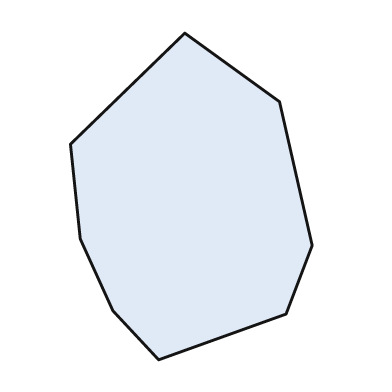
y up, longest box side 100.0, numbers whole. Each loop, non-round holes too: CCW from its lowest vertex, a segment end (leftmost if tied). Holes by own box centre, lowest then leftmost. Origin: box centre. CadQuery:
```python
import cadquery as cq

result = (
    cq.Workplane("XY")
    .moveTo(-10.0, -50.0)
    .lineTo(29.0, -36.0)
    .lineTo(37.0, -15.0)
    .lineTo(27.0, 29.0)
    .lineTo(-2.0, 50.0)
    .lineTo(-37.0, 16.0)
    .lineTo(-34.0, -13.0)
    .lineTo(-24.0, -35.0)
    .close()
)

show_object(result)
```